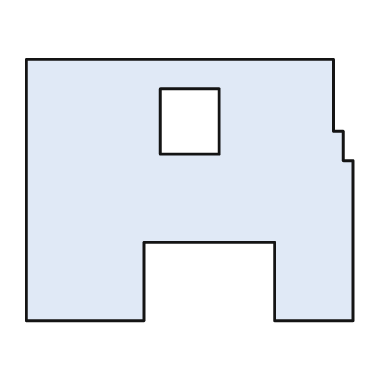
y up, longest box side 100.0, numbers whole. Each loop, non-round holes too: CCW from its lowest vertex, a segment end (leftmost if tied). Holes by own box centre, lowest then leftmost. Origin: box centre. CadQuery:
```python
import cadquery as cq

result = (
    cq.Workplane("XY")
    .moveTo(-50.0, -40.0)
    .lineTo(-14.0, -40.0)
    .lineTo(-14.0, -16.0)
    .lineTo(26.0, -16.0)
    .lineTo(26.0, -40.0)
    .lineTo(50.0, -40.0)
    .lineTo(50.0, 9.0)
    .lineTo(47.0, 9.0)
    .lineTo(47.0, 18.0)
    .lineTo(44.0, 18.0)
    .lineTo(44.0, 40.0)
    .lineTo(-50.0, 40.0)
    .close()
    .moveTo(-9.0, 11.0)
    .lineTo(9.0, 11.0)
    .lineTo(9.0, 31.0)
    .lineTo(-9.0, 31.0)
    .close()
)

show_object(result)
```